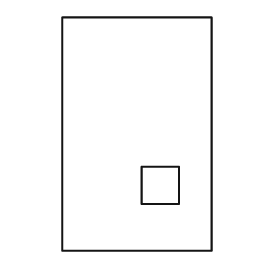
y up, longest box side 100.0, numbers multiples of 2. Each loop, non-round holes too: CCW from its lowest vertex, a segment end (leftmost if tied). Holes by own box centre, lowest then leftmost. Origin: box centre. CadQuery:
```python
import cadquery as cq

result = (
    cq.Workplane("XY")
    .moveTo(-32.0, -50.0)
    .lineTo(32.0, -50.0)
    .lineTo(32.0, 50.0)
    .lineTo(-32.0, 50.0)
    .close()
    .moveTo(2.0, -30.0)
    .lineTo(18.0, -30.0)
    .lineTo(18.0, -14.0)
    .lineTo(2.0, -14.0)
    .close()
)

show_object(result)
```